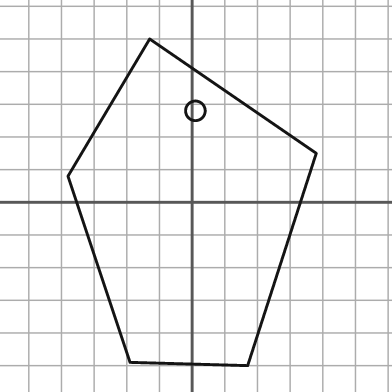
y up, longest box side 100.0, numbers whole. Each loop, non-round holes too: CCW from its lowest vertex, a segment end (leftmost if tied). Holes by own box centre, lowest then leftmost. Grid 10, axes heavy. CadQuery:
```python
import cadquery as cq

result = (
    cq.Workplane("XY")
    .moveTo(17.0, -50.0)
    .lineTo(38.0, 15.0)
    .lineTo(-13.0, 50.0)
    .lineTo(-38.0, 8.0)
    .lineTo(-19.0, -49.0)
    .close()
    .moveTo(1.0, 28.0)
    .circle(3.0)
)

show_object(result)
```